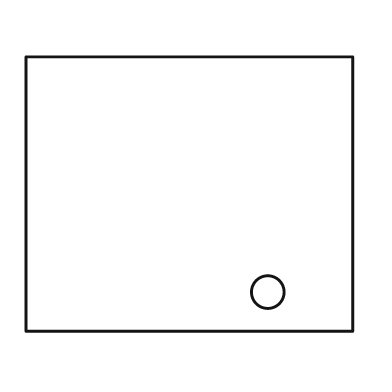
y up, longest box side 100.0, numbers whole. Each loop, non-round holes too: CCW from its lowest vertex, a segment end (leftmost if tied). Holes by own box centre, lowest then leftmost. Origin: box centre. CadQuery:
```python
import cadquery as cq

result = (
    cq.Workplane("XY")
    .moveTo(-50.0, -42.0)
    .lineTo(50.0, -42.0)
    .lineTo(50.0, 42.0)
    .lineTo(-50.0, 42.0)
    .close()
    .moveTo(24.0, -30.0)
    .circle(5.0)
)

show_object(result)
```